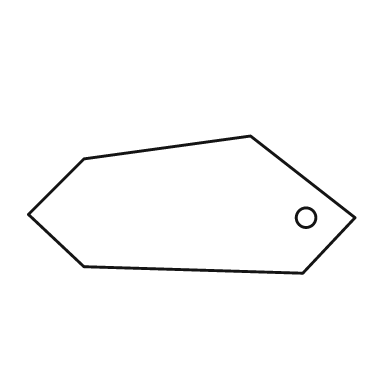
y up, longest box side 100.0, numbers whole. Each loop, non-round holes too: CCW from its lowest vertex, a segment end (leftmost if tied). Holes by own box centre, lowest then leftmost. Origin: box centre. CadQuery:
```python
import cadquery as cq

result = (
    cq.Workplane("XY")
    .moveTo(34.0, -21.0)
    .lineTo(50.0, -4.0)
    .lineTo(18.0, 21.0)
    .lineTo(-33.0, 14.0)
    .lineTo(-50.0, -3.0)
    .lineTo(-33.0, -19.0)
    .close()
    .moveTo(35.0, -4.0)
    .circle(3.0)
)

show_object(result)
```